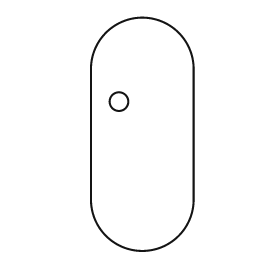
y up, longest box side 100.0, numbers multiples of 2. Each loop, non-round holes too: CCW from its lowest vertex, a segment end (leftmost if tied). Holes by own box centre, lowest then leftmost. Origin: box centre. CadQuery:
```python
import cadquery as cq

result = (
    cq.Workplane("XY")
    .moveTo(-22.0, -28.0)
    .threePointArc((0.0, -50.0), (22.0, -28.0))
    .lineTo(22.0, 28.0)
    .threePointArc((0.0, 50.0), (-22.0, 28.0))
    .close()
    .moveTo(-10.0, 14.0)
    .circle(4.0)
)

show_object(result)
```